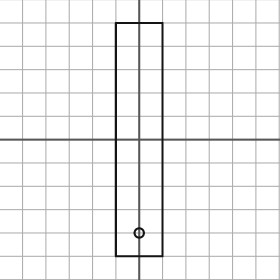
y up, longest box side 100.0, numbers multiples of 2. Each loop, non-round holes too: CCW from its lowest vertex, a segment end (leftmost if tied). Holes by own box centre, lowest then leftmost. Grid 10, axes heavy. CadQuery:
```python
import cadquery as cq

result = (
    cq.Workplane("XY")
    .moveTo(-10.0, -50.0)
    .lineTo(10.0, -50.0)
    .lineTo(10.0, 50.0)
    .lineTo(-10.0, 50.0)
    .close()
    .moveTo(0.0, -40.0)
    .circle(2.0)
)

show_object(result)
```